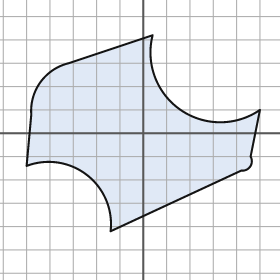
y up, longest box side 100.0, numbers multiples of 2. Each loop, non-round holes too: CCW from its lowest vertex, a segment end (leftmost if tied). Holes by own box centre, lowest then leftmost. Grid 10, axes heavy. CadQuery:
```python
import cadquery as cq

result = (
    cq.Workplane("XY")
    .moveTo(-14.0, -42.0)
    .lineTo(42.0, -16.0)
    .threePointArc((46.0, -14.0), (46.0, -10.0))
    .lineTo(50.0, 10.0)
    .threePointArc((16.0, 10.0), (4.0, 42.0))
    .lineTo(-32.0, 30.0)
    .threePointArc((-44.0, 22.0), (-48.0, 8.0))
    .lineTo(-50.0, -14.0)
    .threePointArc((-24.0, -18.0), (-14.0, -42.0))
    .close()
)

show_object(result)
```